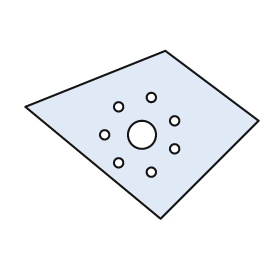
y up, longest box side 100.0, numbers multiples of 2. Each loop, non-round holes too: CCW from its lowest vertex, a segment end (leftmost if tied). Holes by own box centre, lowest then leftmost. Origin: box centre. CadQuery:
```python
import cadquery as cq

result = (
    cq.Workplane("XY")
    .moveTo(8.0, -36.0)
    .lineTo(50.0, 6.0)
    .lineTo(10.0, 36.0)
    .lineTo(-50.0, 12.0)
    .close()
    .moveTo(4.0, -16.0)
    .circle(2.0)
    .moveTo(-10.0, -12.0)
    .circle(2.0)
    .moveTo(14.0, -6.0)
    .circle(2.0)
    .moveTo(-16.0, 0.0)
    .circle(2.0)
    .moveTo(0.0, 0.0)
    .circle(6.0)
    .moveTo(14.0, 6.0)
    .circle(2.0)
    .moveTo(-10.0, 12.0)
    .circle(2.0)
    .moveTo(4.0, 16.0)
    .circle(2.0)
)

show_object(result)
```